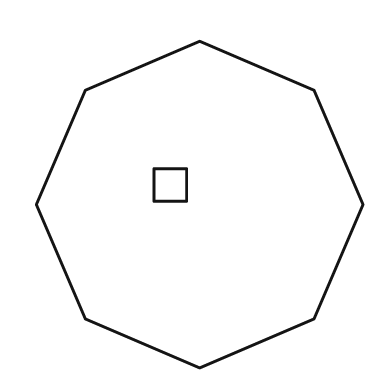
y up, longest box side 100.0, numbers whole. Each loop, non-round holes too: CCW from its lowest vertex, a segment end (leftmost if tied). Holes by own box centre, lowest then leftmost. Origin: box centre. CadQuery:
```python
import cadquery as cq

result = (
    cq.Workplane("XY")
    .moveTo(0.0, -50.0)
    .lineTo(35.0, -35.0)
    .lineTo(50.0, 0.0)
    .lineTo(35.0, 35.0)
    .lineTo(0.0, 50.0)
    .lineTo(-35.0, 35.0)
    .lineTo(-50.0, 0.0)
    .lineTo(-35.0, -35.0)
    .close()
    .moveTo(-14.0, 1.0)
    .lineTo(-4.0, 1.0)
    .lineTo(-4.0, 11.0)
    .lineTo(-14.0, 11.0)
    .close()
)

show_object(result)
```